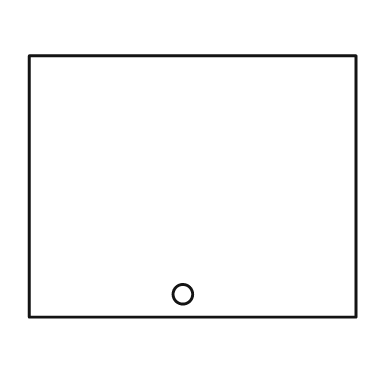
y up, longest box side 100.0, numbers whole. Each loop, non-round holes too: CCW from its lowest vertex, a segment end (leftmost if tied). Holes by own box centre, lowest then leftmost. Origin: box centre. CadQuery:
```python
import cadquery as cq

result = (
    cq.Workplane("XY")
    .moveTo(-50.0, -40.0)
    .lineTo(50.0, -40.0)
    .lineTo(50.0, 40.0)
    .lineTo(-50.0, 40.0)
    .close()
    .moveTo(-3.0, -33.0)
    .circle(3.0)
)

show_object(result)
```